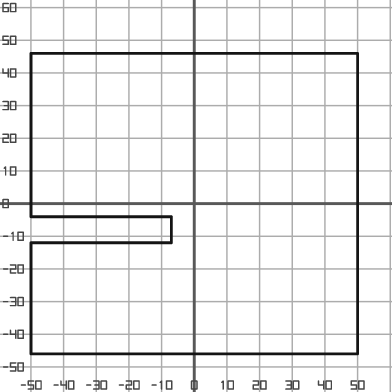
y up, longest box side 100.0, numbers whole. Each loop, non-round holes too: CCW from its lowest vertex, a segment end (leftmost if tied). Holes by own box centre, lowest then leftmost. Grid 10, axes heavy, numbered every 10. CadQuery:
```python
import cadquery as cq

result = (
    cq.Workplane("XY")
    .moveTo(-50.0, -46.0)
    .lineTo(50.0, -46.0)
    .lineTo(50.0, 46.0)
    .lineTo(-50.0, 46.0)
    .lineTo(-50.0, -4.0)
    .lineTo(-7.0, -4.0)
    .lineTo(-7.0, -12.0)
    .lineTo(-50.0, -12.0)
    .close()
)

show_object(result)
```